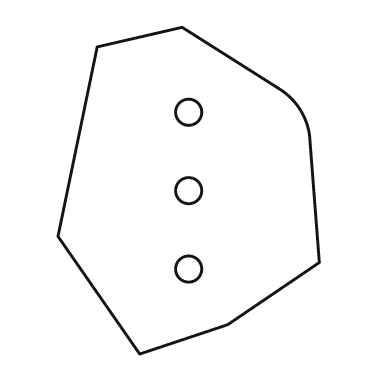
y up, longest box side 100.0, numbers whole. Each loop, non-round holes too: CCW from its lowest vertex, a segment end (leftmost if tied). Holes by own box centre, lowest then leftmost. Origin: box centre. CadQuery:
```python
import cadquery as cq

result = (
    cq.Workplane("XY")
    .moveTo(-15.0, -50.0)
    .lineTo(12.0, -41.0)
    .lineTo(40.0, -22.0)
    .lineTo(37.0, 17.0)
    .threePointArc((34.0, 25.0), (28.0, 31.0))
    .lineTo(-2.0, 50.0)
    .lineTo(-28.0, 44.0)
    .lineTo(-40.0, -14.0)
    .close()
    .moveTo(0.0, -24.0)
    .circle(4.0)
    .moveTo(0.0, 0.0)
    .circle(4.0)
    .moveTo(0.0, 24.0)
    .circle(4.0)
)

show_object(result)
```